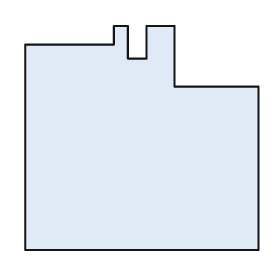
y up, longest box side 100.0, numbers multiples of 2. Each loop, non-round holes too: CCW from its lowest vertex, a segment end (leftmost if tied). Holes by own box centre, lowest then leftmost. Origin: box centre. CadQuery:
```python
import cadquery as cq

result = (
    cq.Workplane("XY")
    .moveTo(-50.0, -48.0)
    .lineTo(50.0, -48.0)
    .lineTo(50.0, 22.0)
    .lineTo(14.0, 22.0)
    .lineTo(14.0, 48.0)
    .lineTo(2.0, 48.0)
    .lineTo(2.0, 34.0)
    .lineTo(-6.0, 34.0)
    .lineTo(-6.0, 48.0)
    .lineTo(-12.0, 48.0)
    .lineTo(-12.0, 40.0)
    .lineTo(-50.0, 40.0)
    .close()
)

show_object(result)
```